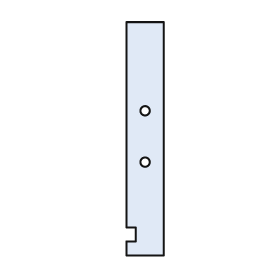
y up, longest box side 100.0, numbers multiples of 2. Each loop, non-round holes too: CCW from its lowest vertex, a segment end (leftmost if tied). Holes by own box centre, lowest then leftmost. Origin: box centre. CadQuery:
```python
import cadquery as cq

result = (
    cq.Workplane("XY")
    .moveTo(-8.0, -50.0)
    .lineTo(8.0, -50.0)
    .lineTo(8.0, 50.0)
    .lineTo(-8.0, 50.0)
    .lineTo(-8.0, -38.0)
    .lineTo(-4.0, -38.0)
    .lineTo(-4.0, -44.0)
    .lineTo(-8.0, -44.0)
    .close()
    .moveTo(0.0, -10.0)
    .circle(2.0)
    .moveTo(0.0, 12.0)
    .circle(2.0)
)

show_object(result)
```